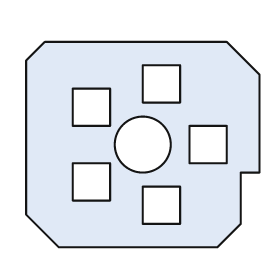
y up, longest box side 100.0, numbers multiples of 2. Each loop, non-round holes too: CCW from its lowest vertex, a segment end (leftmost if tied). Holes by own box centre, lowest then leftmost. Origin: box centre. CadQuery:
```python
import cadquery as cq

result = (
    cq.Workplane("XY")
    .moveTo(-36.0, -44.0)
    .lineTo(32.0, -44.0)
    .lineTo(42.0, -34.0)
    .lineTo(42.0, -12.0)
    .lineTo(50.0, -12.0)
    .lineTo(50.0, 30.0)
    .lineTo(36.0, 44.0)
    .lineTo(-42.0, 44.0)
    .lineTo(-50.0, 36.0)
    .lineTo(-50.0, -30.0)
    .close()
    .moveTo(0.0, -34.0)
    .lineTo(16.0, -34.0)
    .lineTo(16.0, -18.0)
    .lineTo(0.0, -18.0)
    .close()
    .moveTo(-30.0, -24.0)
    .lineTo(-14.0, -24.0)
    .lineTo(-14.0, -8.0)
    .lineTo(-30.0, -8.0)
    .close()
    .moveTo(0.0, 0.0)
    .circle(12.0)
    .moveTo(20.0, -8.0)
    .lineTo(36.0, -8.0)
    .lineTo(36.0, 8.0)
    .lineTo(20.0, 8.0)
    .close()
    .moveTo(-30.0, 8.0)
    .lineTo(-14.0, 8.0)
    .lineTo(-14.0, 24.0)
    .lineTo(-30.0, 24.0)
    .close()
    .moveTo(0.0, 18.0)
    .lineTo(16.0, 18.0)
    .lineTo(16.0, 34.0)
    .lineTo(0.0, 34.0)
    .close()
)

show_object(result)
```